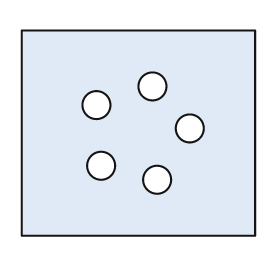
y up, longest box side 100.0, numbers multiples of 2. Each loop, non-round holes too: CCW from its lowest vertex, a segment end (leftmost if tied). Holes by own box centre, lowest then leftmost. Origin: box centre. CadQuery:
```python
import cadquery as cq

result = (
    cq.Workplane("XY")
    .moveTo(-50.0, -44.0)
    .lineTo(50.0, -44.0)
    .lineTo(50.0, 44.0)
    .lineTo(-50.0, 44.0)
    .close()
    .moveTo(8.0, -20.0)
    .circle(6.0)
    .moveTo(-16.0, -14.0)
    .circle(6.0)
    .moveTo(22.0, 2.0)
    .circle(6.0)
    .moveTo(-18.0, 12.0)
    .circle(6.0)
    .moveTo(6.0, 20.0)
    .circle(6.0)
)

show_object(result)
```